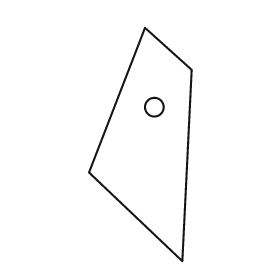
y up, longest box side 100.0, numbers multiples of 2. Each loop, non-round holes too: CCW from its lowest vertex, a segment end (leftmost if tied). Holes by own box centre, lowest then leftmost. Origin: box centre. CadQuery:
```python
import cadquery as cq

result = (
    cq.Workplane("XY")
    .moveTo(18.0, -50.0)
    .lineTo(22.0, 32.0)
    .lineTo(2.0, 50.0)
    .lineTo(-22.0, -12.0)
    .close()
    .moveTo(6.0, 16.0)
    .circle(4.0)
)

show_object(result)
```